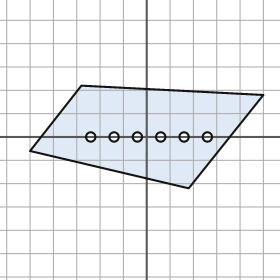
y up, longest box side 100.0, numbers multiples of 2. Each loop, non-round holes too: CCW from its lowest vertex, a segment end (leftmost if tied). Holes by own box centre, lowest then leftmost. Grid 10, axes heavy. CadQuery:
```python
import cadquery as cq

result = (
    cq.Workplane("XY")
    .moveTo(18.0, -22.0)
    .lineTo(50.0, 18.0)
    .lineTo(-28.0, 22.0)
    .lineTo(-50.0, -6.0)
    .close()
    .moveTo(-24.0, 0.0)
    .circle(2.0)
    .moveTo(-14.0, 0.0)
    .circle(2.0)
    .moveTo(-4.0, 0.0)
    .circle(2.0)
    .moveTo(6.0, 0.0)
    .circle(2.0)
    .moveTo(16.0, 0.0)
    .circle(2.0)
    .moveTo(26.0, 0.0)
    .circle(2.0)
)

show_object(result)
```